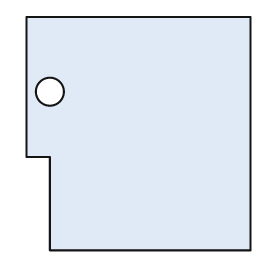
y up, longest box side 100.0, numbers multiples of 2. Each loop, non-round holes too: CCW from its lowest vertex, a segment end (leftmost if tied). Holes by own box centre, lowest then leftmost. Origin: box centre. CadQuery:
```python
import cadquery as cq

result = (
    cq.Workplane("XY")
    .moveTo(-38.0, -50.0)
    .lineTo(48.0, -50.0)
    .lineTo(48.0, 50.0)
    .lineTo(-48.0, 50.0)
    .lineTo(-48.0, -10.0)
    .lineTo(-38.0, -10.0)
    .close()
    .moveTo(-38.0, 18.0)
    .circle(6.0)
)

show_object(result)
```